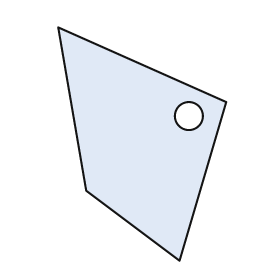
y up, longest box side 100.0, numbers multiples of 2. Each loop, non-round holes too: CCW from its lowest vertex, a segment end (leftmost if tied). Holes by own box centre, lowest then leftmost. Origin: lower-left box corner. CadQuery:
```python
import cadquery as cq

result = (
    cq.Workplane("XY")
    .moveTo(52.0, 0.0)
    .lineTo(72.0, 68.0)
    .lineTo(0.0, 100.0)
    .lineTo(12.0, 30.0)
    .close()
    .moveTo(56.0, 62.0)
    .circle(6.0)
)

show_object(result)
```